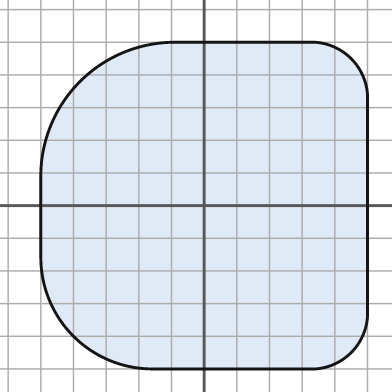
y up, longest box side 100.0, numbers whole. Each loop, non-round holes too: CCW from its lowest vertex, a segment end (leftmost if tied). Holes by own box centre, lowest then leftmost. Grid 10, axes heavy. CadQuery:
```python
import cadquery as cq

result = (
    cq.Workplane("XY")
    .moveTo(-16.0, -50.0)
    .lineTo(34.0, -50.0)
    .threePointArc((45.0, -45.0), (50.0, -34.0))
    .lineTo(50.0, 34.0)
    .threePointArc((45.0, 45.0), (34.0, 50.0))
    .lineTo(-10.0, 50.0)
    .threePointArc((-38.0, 38.0), (-50.0, 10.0))
    .lineTo(-50.0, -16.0)
    .threePointArc((-40.0, -40.0), (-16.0, -50.0))
    .close()
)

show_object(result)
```